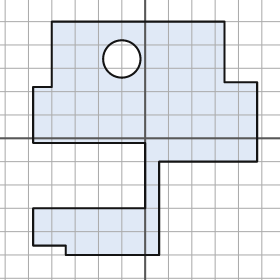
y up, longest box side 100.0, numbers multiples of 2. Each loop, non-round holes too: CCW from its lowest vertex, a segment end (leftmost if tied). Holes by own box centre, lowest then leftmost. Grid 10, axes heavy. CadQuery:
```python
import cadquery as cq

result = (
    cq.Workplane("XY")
    .moveTo(-34.0, -50.0)
    .lineTo(6.0, -50.0)
    .lineTo(6.0, -10.0)
    .lineTo(48.0, -10.0)
    .lineTo(48.0, 24.0)
    .lineTo(34.0, 24.0)
    .lineTo(34.0, 50.0)
    .lineTo(-40.0, 50.0)
    .lineTo(-40.0, 22.0)
    .lineTo(-48.0, 22.0)
    .lineTo(-48.0, -2.0)
    .lineTo(0.0, -2.0)
    .lineTo(0.0, -30.0)
    .lineTo(-48.0, -30.0)
    .lineTo(-48.0, -46.0)
    .lineTo(-34.0, -46.0)
    .close()
    .moveTo(-10.0, 34.0)
    .circle(8.0)
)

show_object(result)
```